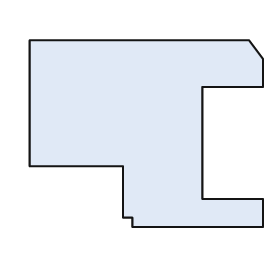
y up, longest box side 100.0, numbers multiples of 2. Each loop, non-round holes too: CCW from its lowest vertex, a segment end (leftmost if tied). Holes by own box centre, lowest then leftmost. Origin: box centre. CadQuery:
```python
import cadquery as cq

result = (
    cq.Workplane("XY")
    .moveTo(-6.0, -40.0)
    .lineTo(50.0, -40.0)
    .lineTo(50.0, -28.0)
    .lineTo(24.0, -28.0)
    .lineTo(24.0, 20.0)
    .lineTo(50.0, 20.0)
    .lineTo(50.0, 32.0)
    .lineTo(44.0, 40.0)
    .lineTo(-50.0, 40.0)
    .lineTo(-50.0, -14.0)
    .lineTo(-10.0, -14.0)
    .lineTo(-10.0, -36.0)
    .lineTo(-6.0, -36.0)
    .close()
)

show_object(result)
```